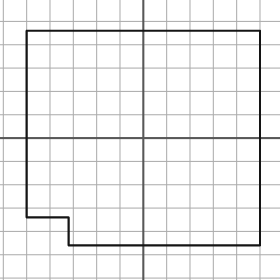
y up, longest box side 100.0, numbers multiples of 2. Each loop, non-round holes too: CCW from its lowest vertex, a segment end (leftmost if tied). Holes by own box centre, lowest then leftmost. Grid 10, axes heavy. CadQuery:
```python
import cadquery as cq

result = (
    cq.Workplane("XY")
    .moveTo(-32.0, -46.0)
    .lineTo(50.0, -46.0)
    .lineTo(50.0, 46.0)
    .lineTo(-50.0, 46.0)
    .lineTo(-50.0, -34.0)
    .lineTo(-32.0, -34.0)
    .close()
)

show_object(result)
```